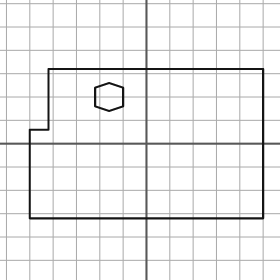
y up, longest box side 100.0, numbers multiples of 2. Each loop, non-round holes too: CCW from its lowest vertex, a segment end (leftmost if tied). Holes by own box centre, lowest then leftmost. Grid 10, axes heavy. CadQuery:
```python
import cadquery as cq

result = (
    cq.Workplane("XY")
    .moveTo(-50.0, -32.0)
    .lineTo(50.0, -32.0)
    .lineTo(50.0, 32.0)
    .lineTo(-42.0, 32.0)
    .lineTo(-42.0, 6.0)
    .lineTo(-50.0, 6.0)
    .close()
    .moveTo(-16.0, 14.0)
    .lineTo(-10.0, 16.0)
    .lineTo(-10.0, 24.0)
    .lineTo(-16.0, 26.0)
    .lineTo(-22.0, 24.0)
    .lineTo(-22.0, 16.0)
    .close()
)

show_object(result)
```